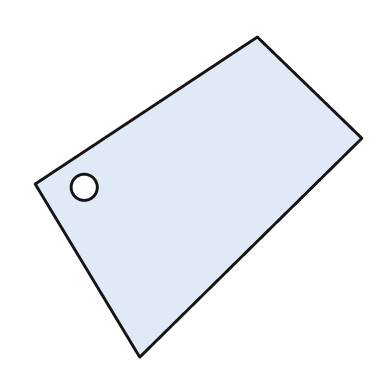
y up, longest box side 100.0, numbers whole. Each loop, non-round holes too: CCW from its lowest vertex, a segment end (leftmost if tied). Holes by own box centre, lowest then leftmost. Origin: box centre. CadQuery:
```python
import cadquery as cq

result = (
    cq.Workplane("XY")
    .moveTo(-18.0, -49.0)
    .lineTo(50.0, 18.0)
    .lineTo(18.0, 49.0)
    .lineTo(-50.0, 4.0)
    .close()
    .moveTo(-35.0, 3.0)
    .circle(4.0)
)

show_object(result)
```